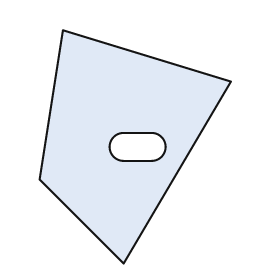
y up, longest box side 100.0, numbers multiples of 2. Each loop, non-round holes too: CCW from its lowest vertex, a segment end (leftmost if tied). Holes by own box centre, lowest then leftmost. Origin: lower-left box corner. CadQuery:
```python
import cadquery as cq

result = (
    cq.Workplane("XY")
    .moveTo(36.0, 0.0)
    .lineTo(82.0, 78.0)
    .lineTo(10.0, 100.0)
    .lineTo(0.0, 36.0)
    .close()
    .moveTo(36.0, 44.0)
    .lineTo(48.0, 44.0)
    .threePointArc((54.0, 50.0), (48.0, 56.0))
    .lineTo(36.0, 56.0)
    .threePointArc((30.0, 50.0), (36.0, 44.0))
    .close()
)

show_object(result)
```